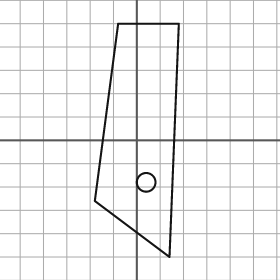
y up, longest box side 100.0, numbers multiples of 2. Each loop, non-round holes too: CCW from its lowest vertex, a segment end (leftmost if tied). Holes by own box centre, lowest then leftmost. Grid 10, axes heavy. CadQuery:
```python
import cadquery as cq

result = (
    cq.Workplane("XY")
    .moveTo(14.0, -50.0)
    .lineTo(18.0, 50.0)
    .lineTo(-8.0, 50.0)
    .lineTo(-18.0, -26.0)
    .close()
    .moveTo(4.0, -18.0)
    .circle(4.0)
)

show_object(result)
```